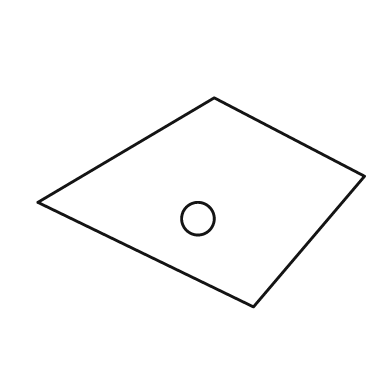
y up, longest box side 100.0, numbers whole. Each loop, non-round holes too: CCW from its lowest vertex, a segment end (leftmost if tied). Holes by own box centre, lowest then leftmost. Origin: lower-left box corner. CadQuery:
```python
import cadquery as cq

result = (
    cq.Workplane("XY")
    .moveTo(66.0, 0.0)
    .lineTo(100.0, 40.0)
    .lineTo(54.0, 64.0)
    .lineTo(0.0, 32.0)
    .close()
    .moveTo(49.0, 27.0)
    .circle(5.0)
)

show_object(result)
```